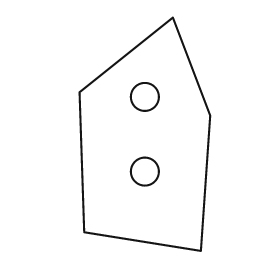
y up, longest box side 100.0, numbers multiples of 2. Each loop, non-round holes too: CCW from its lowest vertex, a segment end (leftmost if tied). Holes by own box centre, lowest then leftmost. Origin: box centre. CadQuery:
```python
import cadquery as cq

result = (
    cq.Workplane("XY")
    .moveTo(24.0, -50.0)
    .lineTo(28.0, 8.0)
    .lineTo(12.0, 50.0)
    .lineTo(-28.0, 18.0)
    .lineTo(-26.0, -42.0)
    .close()
    .moveTo(0.0, -16.0)
    .circle(6.0)
    .moveTo(0.0, 16.0)
    .circle(6.0)
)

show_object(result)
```